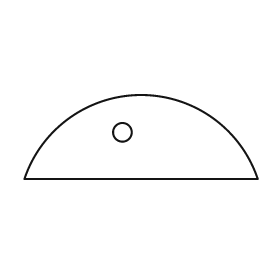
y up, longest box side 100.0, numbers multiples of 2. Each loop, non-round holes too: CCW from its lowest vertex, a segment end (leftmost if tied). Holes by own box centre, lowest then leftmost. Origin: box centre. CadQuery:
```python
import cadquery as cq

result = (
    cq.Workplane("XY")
    .moveTo(-50.0, -18.0)
    .lineTo(50.0, -18.0)
    .threePointArc((0.0, 18.0), (-50.0, -18.0))
    .close()
    .moveTo(-8.0, 2.0)
    .circle(4.0)
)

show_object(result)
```